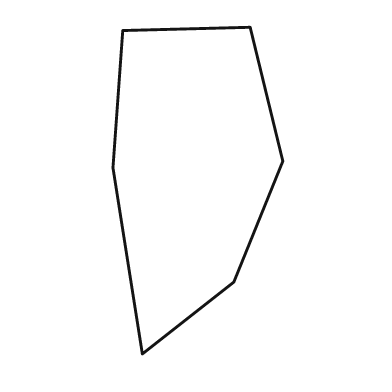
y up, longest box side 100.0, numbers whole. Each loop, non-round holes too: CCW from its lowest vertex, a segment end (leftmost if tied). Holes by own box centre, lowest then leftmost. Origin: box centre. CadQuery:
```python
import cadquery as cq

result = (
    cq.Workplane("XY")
    .moveTo(-17.0, -50.0)
    .lineTo(11.0, -28.0)
    .lineTo(26.0, 9.0)
    .lineTo(16.0, 50.0)
    .lineTo(-23.0, 49.0)
    .lineTo(-26.0, 7.0)
    .close()
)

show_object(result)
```